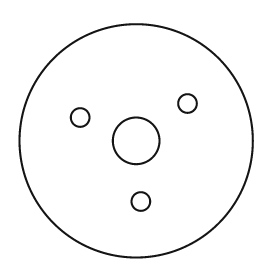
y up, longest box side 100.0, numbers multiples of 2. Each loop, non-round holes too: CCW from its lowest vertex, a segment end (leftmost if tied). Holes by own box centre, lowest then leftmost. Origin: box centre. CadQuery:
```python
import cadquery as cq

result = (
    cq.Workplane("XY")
    .moveTo(0.0, 0.0)
    .circle(50.0)
    .moveTo(2.0, -26.0)
    .circle(4.0)
    .moveTo(0.0, 0.0)
    .circle(10.0)
    .moveTo(-24.0, 10.0)
    .circle(4.0)
    .moveTo(22.0, 16.0)
    .circle(4.0)
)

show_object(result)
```